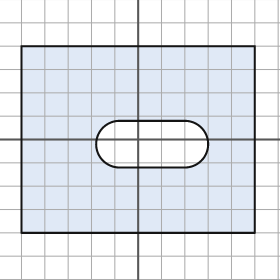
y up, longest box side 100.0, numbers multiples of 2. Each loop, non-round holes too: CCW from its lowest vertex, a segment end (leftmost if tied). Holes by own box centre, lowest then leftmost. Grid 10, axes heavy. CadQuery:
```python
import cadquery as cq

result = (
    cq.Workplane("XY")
    .moveTo(-50.0, -40.0)
    .lineTo(50.0, -40.0)
    .lineTo(50.0, 40.0)
    .lineTo(-50.0, 40.0)
    .close()
    .moveTo(-8.0, -12.0)
    .lineTo(20.0, -12.0)
    .threePointArc((30.0, -2.0), (20.0, 8.0))
    .lineTo(-8.0, 8.0)
    .threePointArc((-18.0, -2.0), (-8.0, -12.0))
    .close()
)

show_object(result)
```